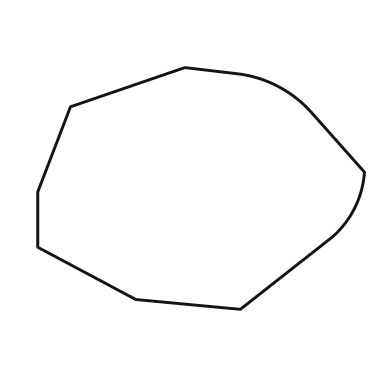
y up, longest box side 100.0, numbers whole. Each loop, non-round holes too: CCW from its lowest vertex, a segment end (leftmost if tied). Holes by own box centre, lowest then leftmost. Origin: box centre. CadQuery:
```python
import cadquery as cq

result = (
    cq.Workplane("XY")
    .moveTo(12.0, -37.0)
    .lineTo(40.0, -15.0)
    .threePointArc((47.0, -6.0), (50.0, 5.0))
    .lineTo(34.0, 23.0)
    .threePointArc((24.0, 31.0), (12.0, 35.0))
    .lineTo(-5.0, 37.0)
    .lineTo(-40.0, 25.0)
    .lineTo(-50.0, -1.0)
    .lineTo(-50.0, -18.0)
    .lineTo(-20.0, -34.0)
    .close()
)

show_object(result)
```